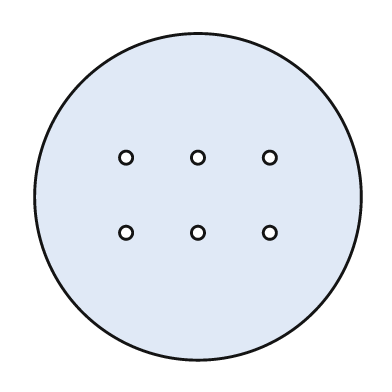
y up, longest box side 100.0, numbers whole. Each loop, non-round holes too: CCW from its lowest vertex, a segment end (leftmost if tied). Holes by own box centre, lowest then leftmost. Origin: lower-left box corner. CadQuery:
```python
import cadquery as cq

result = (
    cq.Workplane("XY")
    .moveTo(50.0, 50.0)
    .circle(50.0)
    .moveTo(28.0, 39.0)
    .circle(2.0)
    .moveTo(50.0, 39.0)
    .circle(2.0)
    .moveTo(72.0, 39.0)
    .circle(2.0)
    .moveTo(28.0, 62.0)
    .circle(2.0)
    .moveTo(50.0, 62.0)
    .circle(2.0)
    .moveTo(72.0, 62.0)
    .circle(2.0)
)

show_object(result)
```